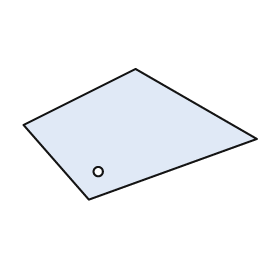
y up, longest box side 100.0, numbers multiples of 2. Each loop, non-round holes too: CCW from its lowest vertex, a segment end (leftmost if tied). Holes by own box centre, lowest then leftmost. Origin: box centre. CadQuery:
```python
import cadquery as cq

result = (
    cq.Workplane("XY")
    .moveTo(-22.0, -28.0)
    .lineTo(50.0, -2.0)
    .lineTo(-2.0, 28.0)
    .lineTo(-50.0, 4.0)
    .close()
    .moveTo(-18.0, -16.0)
    .circle(2.0)
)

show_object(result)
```